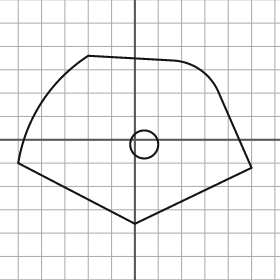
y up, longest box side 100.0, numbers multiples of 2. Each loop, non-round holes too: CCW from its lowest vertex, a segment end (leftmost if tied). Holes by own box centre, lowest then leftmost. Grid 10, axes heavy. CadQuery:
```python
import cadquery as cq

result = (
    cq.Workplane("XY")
    .moveTo(0.0, -36.0)
    .lineTo(50.0, -12.0)
    .lineTo(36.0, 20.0)
    .threePointArc((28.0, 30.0), (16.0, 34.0))
    .lineTo(-20.0, 36.0)
    .threePointArc((-40.0, 16.0), (-50.0, -10.0))
    .close()
    .moveTo(4.0, -2.0)
    .circle(6.0)
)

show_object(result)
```